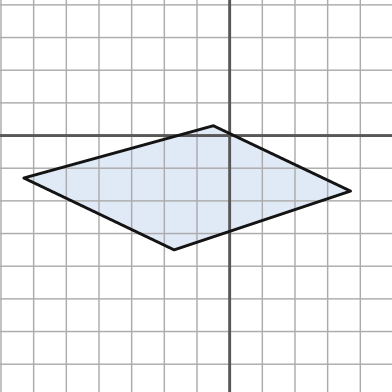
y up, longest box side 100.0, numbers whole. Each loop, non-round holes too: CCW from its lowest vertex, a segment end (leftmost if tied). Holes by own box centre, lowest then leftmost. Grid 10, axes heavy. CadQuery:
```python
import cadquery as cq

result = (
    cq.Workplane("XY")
    .moveTo(-17.0, -35.0)
    .lineTo(37.0, -17.0)
    .lineTo(-5.0, 3.0)
    .lineTo(-63.0, -13.0)
    .close()
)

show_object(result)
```